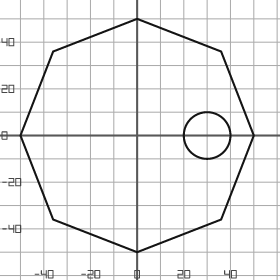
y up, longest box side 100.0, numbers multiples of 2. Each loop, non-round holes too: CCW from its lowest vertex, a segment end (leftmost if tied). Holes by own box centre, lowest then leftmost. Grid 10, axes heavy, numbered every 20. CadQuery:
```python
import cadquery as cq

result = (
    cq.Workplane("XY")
    .moveTo(0.0, -50.0)
    .lineTo(36.0, -36.0)
    .lineTo(50.0, 0.0)
    .lineTo(36.0, 36.0)
    .lineTo(0.0, 50.0)
    .lineTo(-36.0, 36.0)
    .lineTo(-50.0, 0.0)
    .lineTo(-36.0, -36.0)
    .close()
    .moveTo(30.0, 0.0)
    .circle(10.0)
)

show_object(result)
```